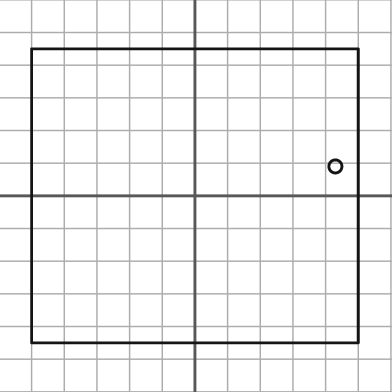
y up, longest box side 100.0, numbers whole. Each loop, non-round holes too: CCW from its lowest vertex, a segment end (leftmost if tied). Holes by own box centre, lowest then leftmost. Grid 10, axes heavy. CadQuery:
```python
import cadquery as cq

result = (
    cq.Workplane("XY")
    .moveTo(-50.0, -45.0)
    .lineTo(50.0, -45.0)
    .lineTo(50.0, 45.0)
    .lineTo(-50.0, 45.0)
    .close()
    .moveTo(43.0, 9.0)
    .circle(2.0)
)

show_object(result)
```